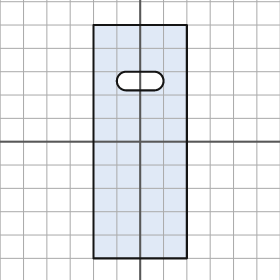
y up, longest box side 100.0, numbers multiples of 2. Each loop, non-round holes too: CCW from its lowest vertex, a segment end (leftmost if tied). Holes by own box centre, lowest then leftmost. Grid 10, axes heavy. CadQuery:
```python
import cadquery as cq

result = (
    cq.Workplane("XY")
    .moveTo(-20.0, -50.0)
    .lineTo(20.0, -50.0)
    .lineTo(20.0, 50.0)
    .lineTo(-20.0, 50.0)
    .close()
    .moveTo(-6.0, 22.0)
    .lineTo(6.0, 22.0)
    .threePointArc((10.0, 26.0), (6.0, 30.0))
    .lineTo(-6.0, 30.0)
    .threePointArc((-10.0, 26.0), (-6.0, 22.0))
    .close()
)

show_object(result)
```